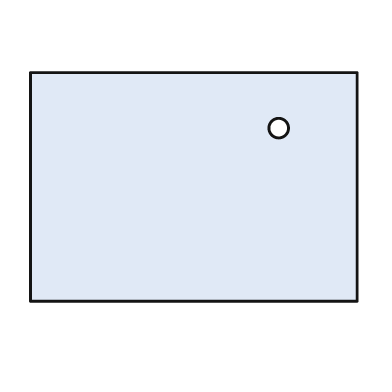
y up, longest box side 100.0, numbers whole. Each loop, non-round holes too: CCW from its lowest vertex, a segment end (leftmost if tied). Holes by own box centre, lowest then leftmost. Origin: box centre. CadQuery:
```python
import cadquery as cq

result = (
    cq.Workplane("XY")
    .moveTo(-50.0, -35.0)
    .lineTo(50.0, -35.0)
    .lineTo(50.0, 35.0)
    .lineTo(-50.0, 35.0)
    .close()
    .moveTo(26.0, 18.0)
    .circle(3.0)
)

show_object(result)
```